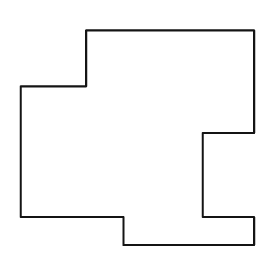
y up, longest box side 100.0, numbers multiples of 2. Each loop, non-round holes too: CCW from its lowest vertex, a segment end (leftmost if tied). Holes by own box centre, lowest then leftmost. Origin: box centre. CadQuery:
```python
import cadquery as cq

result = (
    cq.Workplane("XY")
    .moveTo(-6.0, -46.0)
    .lineTo(50.0, -46.0)
    .lineTo(50.0, -34.0)
    .lineTo(28.0, -34.0)
    .lineTo(28.0, 2.0)
    .lineTo(50.0, 2.0)
    .lineTo(50.0, 46.0)
    .lineTo(-22.0, 46.0)
    .lineTo(-22.0, 22.0)
    .lineTo(-50.0, 22.0)
    .lineTo(-50.0, -34.0)
    .lineTo(-6.0, -34.0)
    .close()
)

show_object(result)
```